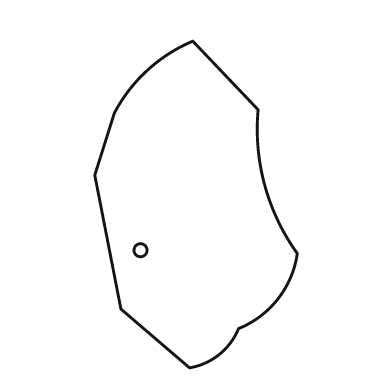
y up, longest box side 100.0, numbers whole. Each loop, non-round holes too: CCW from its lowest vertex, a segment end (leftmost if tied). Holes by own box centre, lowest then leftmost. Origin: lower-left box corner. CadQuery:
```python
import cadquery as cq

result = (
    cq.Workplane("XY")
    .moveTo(29.0, 0.0)
    .threePointArc((38.0, 4.0), (44.0, 12.0))
    .threePointArc((56.0, 21.0), (62.0, 35.0))
    .threePointArc((52.0, 56.0), (50.0, 79.0))
    .lineTo(30.0, 100.0)
    .threePointArc((16.0, 91.0), (6.0, 78.0))
    .lineTo(0.0, 59.0)
    .lineTo(8.0, 18.0)
    .close()
    .moveTo(14.0, 36.0)
    .circle(2.0)
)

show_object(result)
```